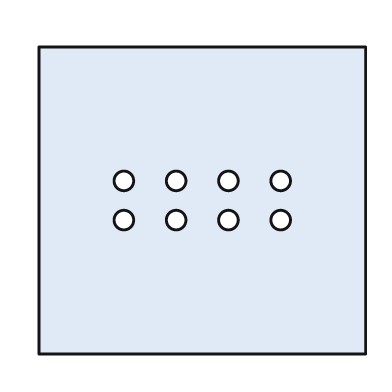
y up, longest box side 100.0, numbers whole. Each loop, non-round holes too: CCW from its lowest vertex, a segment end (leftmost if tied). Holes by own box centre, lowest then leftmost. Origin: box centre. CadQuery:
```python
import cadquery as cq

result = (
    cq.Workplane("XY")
    .moveTo(-50.0, -47.0)
    .lineTo(50.0, -47.0)
    .lineTo(50.0, 47.0)
    .lineTo(-50.0, 47.0)
    .close()
    .moveTo(-24.0, -6.0)
    .circle(3.0)
    .moveTo(-8.0, -6.0)
    .circle(3.0)
    .moveTo(8.0, -6.0)
    .circle(3.0)
    .moveTo(24.0, -6.0)
    .circle(3.0)
    .moveTo(-24.0, 6.0)
    .circle(3.0)
    .moveTo(-8.0, 6.0)
    .circle(3.0)
    .moveTo(8.0, 6.0)
    .circle(3.0)
    .moveTo(24.0, 6.0)
    .circle(3.0)
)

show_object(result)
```